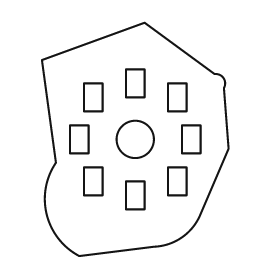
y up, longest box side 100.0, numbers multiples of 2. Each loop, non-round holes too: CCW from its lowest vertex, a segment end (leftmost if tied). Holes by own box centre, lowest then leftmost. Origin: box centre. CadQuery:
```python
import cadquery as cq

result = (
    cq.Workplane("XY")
    .moveTo(-24.0, -50.0)
    .lineTo(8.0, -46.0)
    .threePointArc((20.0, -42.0), (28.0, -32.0))
    .lineTo(40.0, -4.0)
    .lineTo(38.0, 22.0)
    .threePointArc((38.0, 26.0), (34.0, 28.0))
    .lineTo(4.0, 50.0)
    .lineTo(-40.0, 34.0)
    .lineTo(-34.0, -10.0)
    .threePointArc((-38.0, -32.0), (-24.0, -50.0))
    .close()
    .moveTo(-4.0, -30.0)
    .lineTo(4.0, -30.0)
    .lineTo(4.0, -18.0)
    .lineTo(-4.0, -18.0)
    .close()
    .moveTo(-22.0, -24.0)
    .lineTo(-14.0, -24.0)
    .lineTo(-14.0, -12.0)
    .lineTo(-22.0, -12.0)
    .close()
    .moveTo(14.0, -24.0)
    .lineTo(22.0, -24.0)
    .lineTo(22.0, -12.0)
    .lineTo(14.0, -12.0)
    .close()
    .moveTo(-28.0, -6.0)
    .lineTo(-20.0, -6.0)
    .lineTo(-20.0, 6.0)
    .lineTo(-28.0, 6.0)
    .close()
    .moveTo(0.0, 0.0)
    .circle(8.0)
    .moveTo(20.0, -6.0)
    .lineTo(28.0, -6.0)
    .lineTo(28.0, 6.0)
    .lineTo(20.0, 6.0)
    .close()
    .moveTo(-22.0, 12.0)
    .lineTo(-14.0, 12.0)
    .lineTo(-14.0, 24.0)
    .lineTo(-22.0, 24.0)
    .close()
    .moveTo(14.0, 12.0)
    .lineTo(22.0, 12.0)
    .lineTo(22.0, 24.0)
    .lineTo(14.0, 24.0)
    .close()
    .moveTo(-4.0, 18.0)
    .lineTo(4.0, 18.0)
    .lineTo(4.0, 30.0)
    .lineTo(-4.0, 30.0)
    .close()
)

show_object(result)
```